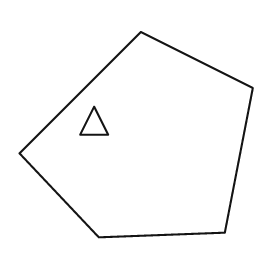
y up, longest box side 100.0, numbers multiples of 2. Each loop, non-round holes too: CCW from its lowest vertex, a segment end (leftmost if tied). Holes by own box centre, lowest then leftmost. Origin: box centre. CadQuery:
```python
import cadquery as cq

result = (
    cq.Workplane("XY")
    .moveTo(-16.0, -44.0)
    .lineTo(38.0, -42.0)
    .lineTo(50.0, 20.0)
    .lineTo(2.0, 44.0)
    .lineTo(-50.0, -8.0)
    .close()
    .moveTo(-24.0, 0.0)
    .lineTo(-12.0, 0.0)
    .lineTo(-18.0, 12.0)
    .close()
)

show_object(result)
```